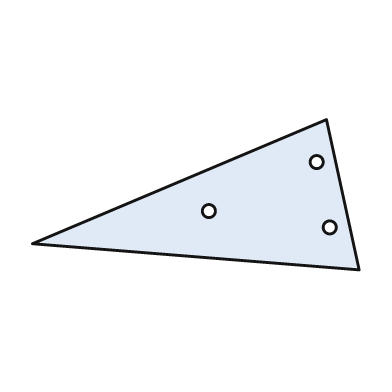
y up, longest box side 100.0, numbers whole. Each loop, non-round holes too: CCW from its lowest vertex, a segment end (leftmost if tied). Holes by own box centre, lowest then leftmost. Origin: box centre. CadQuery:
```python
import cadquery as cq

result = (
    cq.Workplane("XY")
    .moveTo(50.0, -23.0)
    .lineTo(40.0, 23.0)
    .lineTo(-50.0, -15.0)
    .close()
    .moveTo(41.0, -10.0)
    .circle(2.0)
    .moveTo(4.0, -5.0)
    .circle(2.0)
    .moveTo(37.0, 10.0)
    .circle(2.0)
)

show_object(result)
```